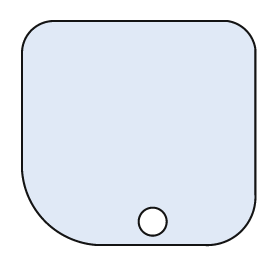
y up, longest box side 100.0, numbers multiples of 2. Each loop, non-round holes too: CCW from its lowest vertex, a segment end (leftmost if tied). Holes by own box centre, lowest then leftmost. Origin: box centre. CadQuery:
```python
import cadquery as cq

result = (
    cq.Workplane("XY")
    .moveTo(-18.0, -48.0)
    .lineTo(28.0, -48.0)
    .threePointArc((44.0, -42.0), (50.0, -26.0))
    .lineTo(50.0, 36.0)
    .threePointArc((46.0, 44.0), (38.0, 48.0))
    .lineTo(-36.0, 48.0)
    .threePointArc((-46.0, 44.0), (-50.0, 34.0))
    .lineTo(-50.0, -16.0)
    .threePointArc((-40.0, -38.0), (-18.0, -48.0))
    .close()
    .moveTo(6.0, -38.0)
    .circle(6.0)
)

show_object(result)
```